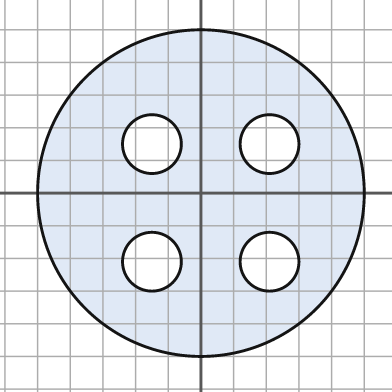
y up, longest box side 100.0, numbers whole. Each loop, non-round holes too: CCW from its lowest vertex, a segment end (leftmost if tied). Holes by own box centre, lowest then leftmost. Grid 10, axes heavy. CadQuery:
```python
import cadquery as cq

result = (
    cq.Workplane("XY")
    .moveTo(0.0, 0.0)
    .circle(50.0)
    .moveTo(-15.0, -21.0)
    .circle(9.0)
    .moveTo(21.0, -21.0)
    .circle(9.0)
    .moveTo(-15.0, 15.0)
    .circle(9.0)
    .moveTo(21.0, 15.0)
    .circle(9.0)
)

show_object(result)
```